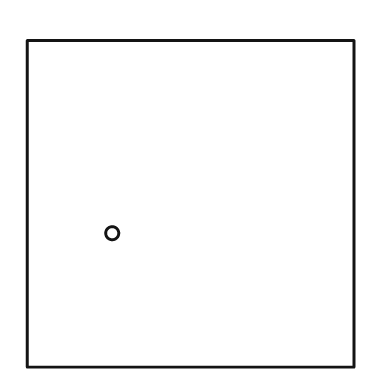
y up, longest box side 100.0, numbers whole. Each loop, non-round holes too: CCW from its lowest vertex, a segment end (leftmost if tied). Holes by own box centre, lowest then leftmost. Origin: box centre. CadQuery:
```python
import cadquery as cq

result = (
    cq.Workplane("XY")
    .moveTo(-50.0, -50.0)
    .lineTo(50.0, -50.0)
    .lineTo(50.0, 50.0)
    .lineTo(-50.0, 50.0)
    .close()
    .moveTo(-24.0, -9.0)
    .circle(2.0)
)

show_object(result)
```